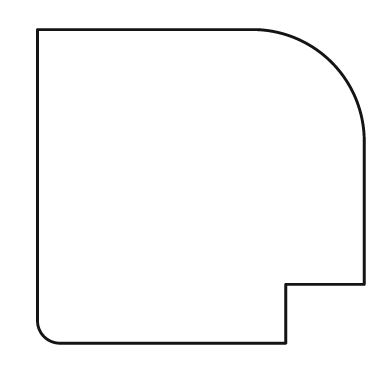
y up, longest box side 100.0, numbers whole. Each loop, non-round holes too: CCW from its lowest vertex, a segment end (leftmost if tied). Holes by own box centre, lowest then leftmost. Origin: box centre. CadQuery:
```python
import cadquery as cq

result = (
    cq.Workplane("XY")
    .moveTo(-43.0, -48.0)
    .lineTo(26.0, -48.0)
    .lineTo(26.0, -30.0)
    .lineTo(50.0, -30.0)
    .lineTo(50.0, 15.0)
    .threePointArc((40.0, 38.0), (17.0, 48.0))
    .lineTo(-50.0, 48.0)
    .lineTo(-50.0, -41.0)
    .threePointArc((-48.0, -46.0), (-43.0, -48.0))
    .close()
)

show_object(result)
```